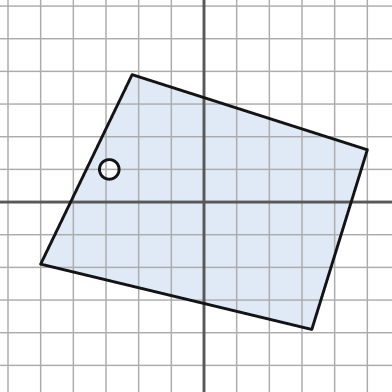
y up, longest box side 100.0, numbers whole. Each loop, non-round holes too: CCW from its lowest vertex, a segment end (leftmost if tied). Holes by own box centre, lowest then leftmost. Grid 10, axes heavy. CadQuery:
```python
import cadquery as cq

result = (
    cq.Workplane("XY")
    .moveTo(33.0, -39.0)
    .lineTo(50.0, 16.0)
    .lineTo(-22.0, 39.0)
    .lineTo(-50.0, -19.0)
    .close()
    .moveTo(-29.0, 10.0)
    .circle(3.0)
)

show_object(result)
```